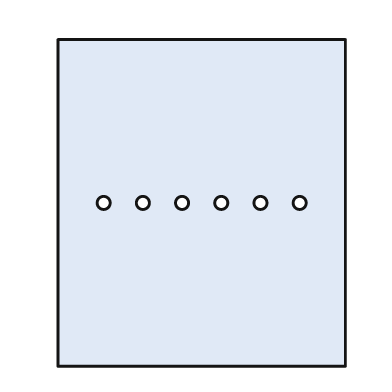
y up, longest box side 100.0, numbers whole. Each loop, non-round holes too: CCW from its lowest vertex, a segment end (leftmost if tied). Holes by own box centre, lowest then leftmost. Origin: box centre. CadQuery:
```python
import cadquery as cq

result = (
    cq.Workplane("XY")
    .moveTo(-44.0, -50.0)
    .lineTo(44.0, -50.0)
    .lineTo(44.0, 50.0)
    .lineTo(-44.0, 50.0)
    .close()
    .moveTo(-30.0, 0.0)
    .circle(2.0)
    .moveTo(-18.0, 0.0)
    .circle(2.0)
    .moveTo(-6.0, 0.0)
    .circle(2.0)
    .moveTo(6.0, 0.0)
    .circle(2.0)
    .moveTo(18.0, 0.0)
    .circle(2.0)
    .moveTo(30.0, 0.0)
    .circle(2.0)
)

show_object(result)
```